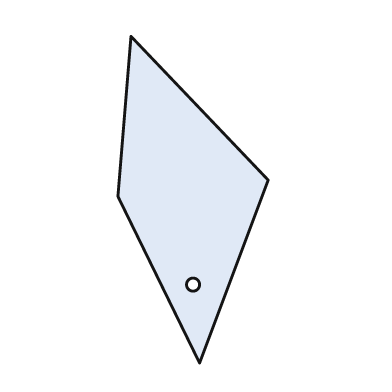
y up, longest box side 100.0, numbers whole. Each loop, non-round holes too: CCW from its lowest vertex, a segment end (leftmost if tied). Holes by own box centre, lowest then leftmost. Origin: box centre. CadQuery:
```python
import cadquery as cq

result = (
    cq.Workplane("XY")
    .moveTo(2.0, -50.0)
    .lineTo(23.0, 6.0)
    .lineTo(-19.0, 50.0)
    .lineTo(-23.0, 1.0)
    .close()
    .moveTo(0.0, -26.0)
    .circle(2.0)
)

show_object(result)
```